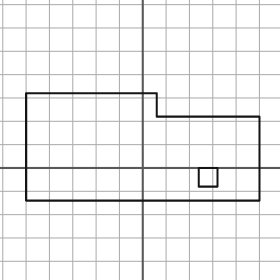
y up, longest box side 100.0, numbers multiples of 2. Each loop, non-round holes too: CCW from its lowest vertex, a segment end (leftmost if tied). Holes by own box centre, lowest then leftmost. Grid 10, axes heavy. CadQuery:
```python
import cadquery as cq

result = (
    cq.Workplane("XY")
    .moveTo(-50.0, -14.0)
    .lineTo(50.0, -14.0)
    .lineTo(50.0, 22.0)
    .lineTo(6.0, 22.0)
    .lineTo(6.0, 32.0)
    .lineTo(-50.0, 32.0)
    .close()
    .moveTo(24.0, -8.0)
    .lineTo(32.0, -8.0)
    .lineTo(32.0, 0.0)
    .lineTo(24.0, 0.0)
    .close()
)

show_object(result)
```